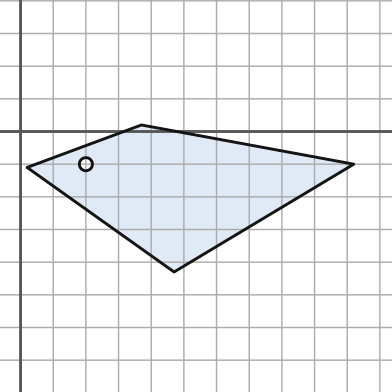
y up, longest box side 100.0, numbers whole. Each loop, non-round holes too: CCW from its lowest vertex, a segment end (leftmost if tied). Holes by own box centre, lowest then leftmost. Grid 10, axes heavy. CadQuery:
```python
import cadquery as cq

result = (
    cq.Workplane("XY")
    .moveTo(47.0, -43.0)
    .lineTo(102.0, -10.0)
    .lineTo(37.0, 2.0)
    .lineTo(2.0, -11.0)
    .close()
    .moveTo(20.0, -10.0)
    .circle(2.0)
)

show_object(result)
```